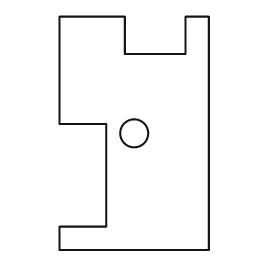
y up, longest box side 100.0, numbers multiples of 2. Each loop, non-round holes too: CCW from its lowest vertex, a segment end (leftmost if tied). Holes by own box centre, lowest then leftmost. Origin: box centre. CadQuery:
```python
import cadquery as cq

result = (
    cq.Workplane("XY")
    .moveTo(-32.0, -50.0)
    .lineTo(32.0, -50.0)
    .lineTo(32.0, 50.0)
    .lineTo(22.0, 50.0)
    .lineTo(22.0, 34.0)
    .lineTo(-4.0, 34.0)
    .lineTo(-4.0, 50.0)
    .lineTo(-32.0, 50.0)
    .lineTo(-32.0, 4.0)
    .lineTo(-12.0, 4.0)
    .lineTo(-12.0, -40.0)
    .lineTo(-32.0, -40.0)
    .close()
    .moveTo(0.0, 0.0)
    .circle(6.0)
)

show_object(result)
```